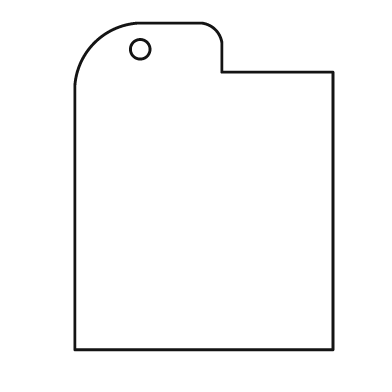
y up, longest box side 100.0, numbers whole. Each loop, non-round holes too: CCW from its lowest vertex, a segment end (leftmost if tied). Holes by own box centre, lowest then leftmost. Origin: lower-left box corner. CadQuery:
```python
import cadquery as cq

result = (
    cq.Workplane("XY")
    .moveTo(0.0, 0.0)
    .lineTo(79.0, 0.0)
    .lineTo(79.0, 85.0)
    .lineTo(45.0, 85.0)
    .lineTo(45.0, 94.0)
    .threePointArc((43.0, 98.0), (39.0, 100.0))
    .lineTo(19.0, 100.0)
    .threePointArc((6.0, 94.0), (0.0, 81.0))
    .close()
    .moveTo(20.0, 92.0)
    .circle(3.0)
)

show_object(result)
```